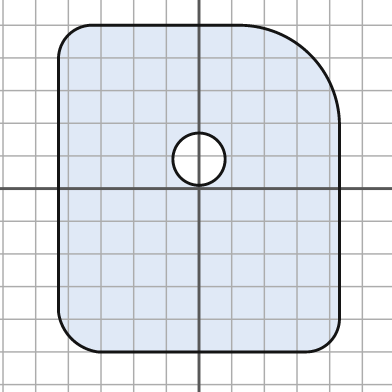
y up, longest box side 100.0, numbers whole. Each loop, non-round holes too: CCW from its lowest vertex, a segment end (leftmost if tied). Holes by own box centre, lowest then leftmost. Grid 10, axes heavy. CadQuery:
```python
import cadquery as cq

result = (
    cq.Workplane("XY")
    .moveTo(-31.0, -50.0)
    .lineTo(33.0, -50.0)
    .threePointArc((40.0, -47.0), (43.0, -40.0))
    .lineTo(43.0, 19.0)
    .threePointArc((34.0, 41.0), (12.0, 50.0))
    .lineTo(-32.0, 50.0)
    .threePointArc((-40.0, 47.0), (-43.0, 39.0))
    .lineTo(-43.0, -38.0)
    .threePointArc((-39.0, -46.0), (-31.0, -50.0))
    .close()
    .moveTo(0.0, 9.0)
    .circle(8.0)
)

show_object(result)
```